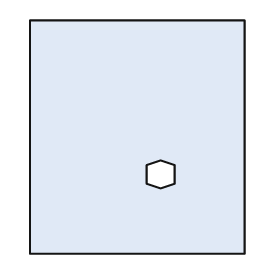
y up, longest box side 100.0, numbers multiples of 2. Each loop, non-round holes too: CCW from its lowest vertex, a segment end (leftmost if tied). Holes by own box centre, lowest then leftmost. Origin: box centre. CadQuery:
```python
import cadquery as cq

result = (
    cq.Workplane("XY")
    .moveTo(-46.0, -50.0)
    .lineTo(46.0, -50.0)
    .lineTo(46.0, 50.0)
    .lineTo(-46.0, 50.0)
    .close()
    .moveTo(10.0, -22.0)
    .lineTo(16.0, -20.0)
    .lineTo(16.0, -12.0)
    .lineTo(10.0, -10.0)
    .lineTo(4.0, -12.0)
    .lineTo(4.0, -20.0)
    .close()
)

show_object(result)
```